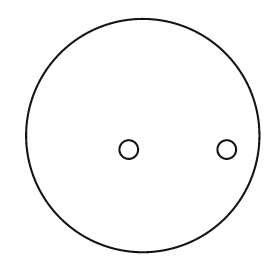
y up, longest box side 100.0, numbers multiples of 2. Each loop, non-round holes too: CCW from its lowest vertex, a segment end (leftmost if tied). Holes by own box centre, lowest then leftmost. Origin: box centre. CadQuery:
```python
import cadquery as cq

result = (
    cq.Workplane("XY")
    .moveTo(0.0, 0.0)
    .circle(50.0)
    .moveTo(-6.0, -6.0)
    .circle(4.0)
    .moveTo(36.0, -6.0)
    .circle(4.0)
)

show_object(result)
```